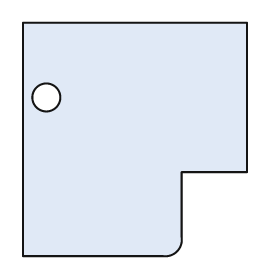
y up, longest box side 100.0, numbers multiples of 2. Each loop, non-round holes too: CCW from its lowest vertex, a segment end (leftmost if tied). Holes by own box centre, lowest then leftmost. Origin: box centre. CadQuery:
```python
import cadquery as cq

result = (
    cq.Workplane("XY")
    .moveTo(-48.0, -50.0)
    .lineTo(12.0, -50.0)
    .threePointArc((18.0, -48.0), (20.0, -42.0))
    .lineTo(20.0, -14.0)
    .lineTo(48.0, -14.0)
    .lineTo(48.0, 50.0)
    .lineTo(-48.0, 50.0)
    .close()
    .moveTo(-38.0, 18.0)
    .circle(6.0)
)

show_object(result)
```